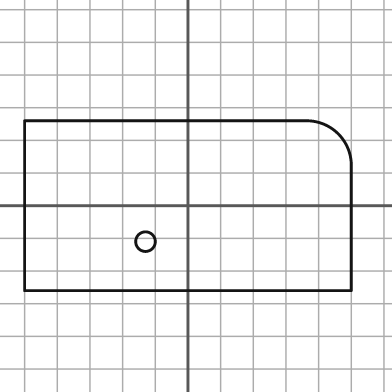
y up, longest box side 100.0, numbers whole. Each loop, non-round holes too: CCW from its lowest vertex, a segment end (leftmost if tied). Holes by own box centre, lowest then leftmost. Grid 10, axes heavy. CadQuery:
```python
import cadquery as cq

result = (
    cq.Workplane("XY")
    .moveTo(-50.0, -26.0)
    .lineTo(50.0, -26.0)
    .lineTo(50.0, 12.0)
    .threePointArc((46.0, 22.0), (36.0, 26.0))
    .lineTo(-50.0, 26.0)
    .close()
    .moveTo(-13.0, -11.0)
    .circle(3.0)
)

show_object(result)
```